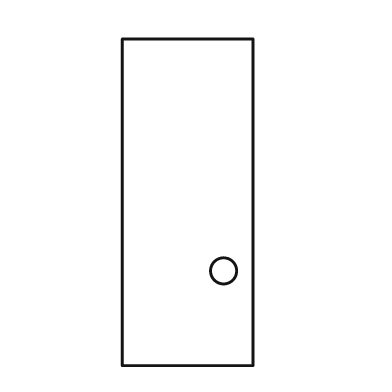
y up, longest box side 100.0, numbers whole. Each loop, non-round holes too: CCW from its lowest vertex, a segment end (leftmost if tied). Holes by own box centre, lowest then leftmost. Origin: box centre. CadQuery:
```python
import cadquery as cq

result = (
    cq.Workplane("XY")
    .moveTo(-20.0, -50.0)
    .lineTo(20.0, -50.0)
    .lineTo(20.0, 50.0)
    .lineTo(-20.0, 50.0)
    .close()
    .moveTo(11.0, -21.0)
    .circle(4.0)
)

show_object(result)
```